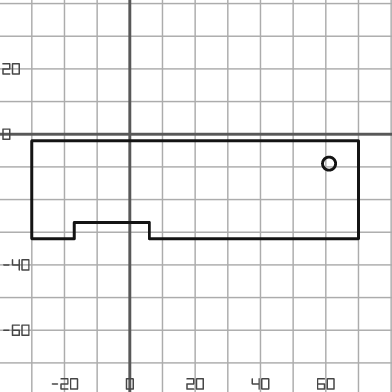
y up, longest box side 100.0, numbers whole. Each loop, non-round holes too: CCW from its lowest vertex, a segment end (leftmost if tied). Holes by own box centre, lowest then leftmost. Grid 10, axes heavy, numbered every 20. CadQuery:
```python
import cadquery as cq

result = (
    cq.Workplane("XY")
    .moveTo(-30.0, -32.0)
    .lineTo(-17.0, -32.0)
    .lineTo(-17.0, -27.0)
    .lineTo(6.0, -27.0)
    .lineTo(6.0, -32.0)
    .lineTo(70.0, -32.0)
    .lineTo(70.0, -2.0)
    .lineTo(-30.0, -2.0)
    .close()
    .moveTo(61.0, -9.0)
    .circle(2.0)
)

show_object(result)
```